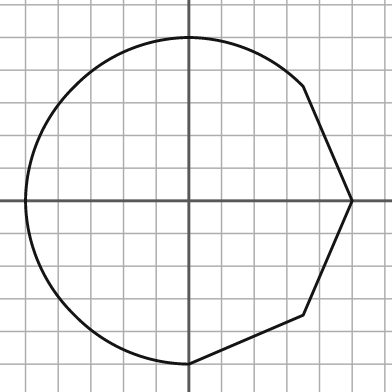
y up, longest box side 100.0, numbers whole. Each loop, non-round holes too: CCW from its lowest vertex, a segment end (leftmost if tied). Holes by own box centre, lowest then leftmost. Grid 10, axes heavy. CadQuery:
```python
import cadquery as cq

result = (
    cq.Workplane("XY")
    .moveTo(0.0, -50.0)
    .lineTo(35.0, -35.0)
    .lineTo(50.0, 0.0)
    .lineTo(35.0, 35.0)
    .threePointArc((19.0, 46.0), (0.0, 50.0))
    .threePointArc((-19.0, 46.0), (-35.0, 35.0))
    .threePointArc((-46.0, 19.0), (-50.0, 0.0))
    .threePointArc((-46.0, -19.0), (-35.0, -35.0))
    .threePointArc((-19.0, -46.0), (0.0, -50.0))
    .close()
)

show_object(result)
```